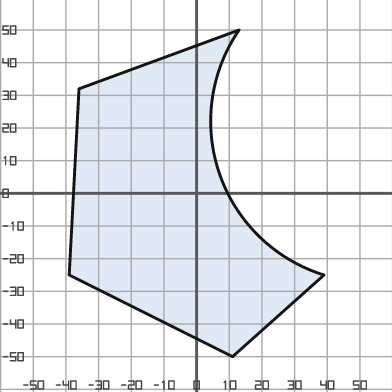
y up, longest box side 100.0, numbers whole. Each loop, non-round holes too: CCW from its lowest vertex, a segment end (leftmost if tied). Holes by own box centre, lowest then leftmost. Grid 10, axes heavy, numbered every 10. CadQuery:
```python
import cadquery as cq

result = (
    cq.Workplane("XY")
    .moveTo(11.0, -50.0)
    .lineTo(39.0, -25.0)
    .threePointArc((7.0, 6.0), (13.0, 50.0))
    .lineTo(-36.0, 32.0)
    .lineTo(-39.0, -25.0)
    .close()
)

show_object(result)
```